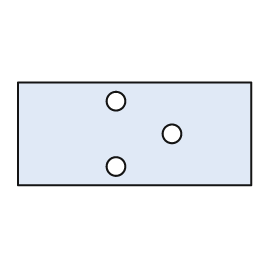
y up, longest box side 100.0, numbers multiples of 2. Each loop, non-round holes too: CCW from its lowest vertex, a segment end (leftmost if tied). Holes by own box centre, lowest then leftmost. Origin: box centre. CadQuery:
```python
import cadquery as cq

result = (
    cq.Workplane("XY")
    .moveTo(-50.0, -22.0)
    .lineTo(50.0, -22.0)
    .lineTo(50.0, 22.0)
    .lineTo(-50.0, 22.0)
    .close()
    .moveTo(-8.0, -14.0)
    .circle(4.0)
    .moveTo(16.0, 0.0)
    .circle(4.0)
    .moveTo(-8.0, 14.0)
    .circle(4.0)
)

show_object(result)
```